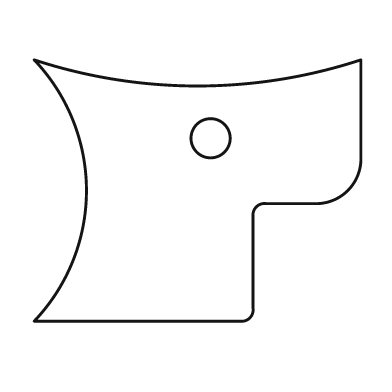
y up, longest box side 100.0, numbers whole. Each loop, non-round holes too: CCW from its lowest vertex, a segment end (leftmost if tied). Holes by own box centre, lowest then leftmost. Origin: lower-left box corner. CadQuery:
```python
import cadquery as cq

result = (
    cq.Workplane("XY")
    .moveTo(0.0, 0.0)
    .lineTo(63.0, 0.0)
    .threePointArc((66.0, 1.0), (67.0, 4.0))
    .lineTo(67.0, 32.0)
    .threePointArc((68.0, 35.0), (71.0, 36.0))
    .lineTo(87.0, 36.0)
    .threePointArc((96.0, 40.0), (100.0, 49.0))
    .lineTo(100.0, 80.0)
    .threePointArc((50.0, 72.0), (0.0, 80.0))
    .threePointArc((16.0, 40.0), (0.0, 0.0))
    .close()
    .moveTo(54.0, 56.0)
    .circle(6.0)
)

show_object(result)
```